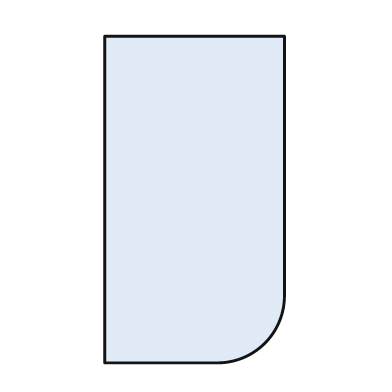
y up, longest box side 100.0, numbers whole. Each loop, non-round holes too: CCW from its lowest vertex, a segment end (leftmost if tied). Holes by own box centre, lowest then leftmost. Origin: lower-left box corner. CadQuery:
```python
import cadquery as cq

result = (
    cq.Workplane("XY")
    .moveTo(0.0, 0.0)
    .lineTo(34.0, 0.0)
    .threePointArc((49.0, 6.0), (55.0, 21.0))
    .lineTo(55.0, 100.0)
    .lineTo(0.0, 100.0)
    .close()
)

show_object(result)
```